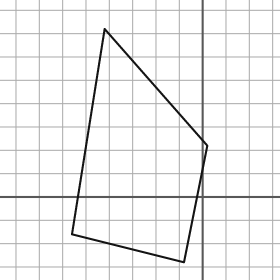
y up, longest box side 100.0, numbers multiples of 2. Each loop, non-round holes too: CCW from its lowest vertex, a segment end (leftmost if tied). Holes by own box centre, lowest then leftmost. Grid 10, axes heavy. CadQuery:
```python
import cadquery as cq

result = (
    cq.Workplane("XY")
    .moveTo(-8.0, -28.0)
    .lineTo(2.0, 22.0)
    .lineTo(-42.0, 72.0)
    .lineTo(-56.0, -16.0)
    .close()
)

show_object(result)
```